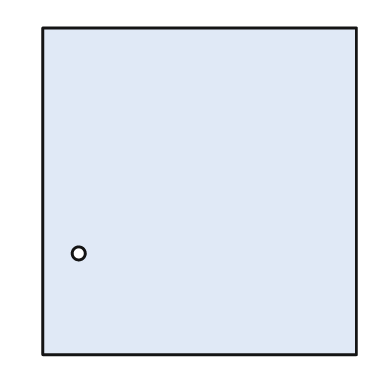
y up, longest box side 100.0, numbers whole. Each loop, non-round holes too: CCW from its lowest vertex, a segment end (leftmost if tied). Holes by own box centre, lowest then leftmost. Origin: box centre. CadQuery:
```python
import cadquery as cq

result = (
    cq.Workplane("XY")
    .moveTo(-48.0, -50.0)
    .lineTo(48.0, -50.0)
    .lineTo(48.0, 50.0)
    .lineTo(-48.0, 50.0)
    .close()
    .moveTo(-37.0, -19.0)
    .circle(2.0)
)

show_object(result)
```